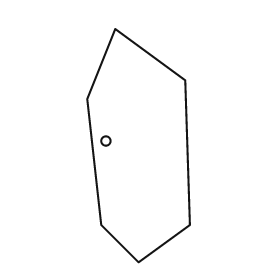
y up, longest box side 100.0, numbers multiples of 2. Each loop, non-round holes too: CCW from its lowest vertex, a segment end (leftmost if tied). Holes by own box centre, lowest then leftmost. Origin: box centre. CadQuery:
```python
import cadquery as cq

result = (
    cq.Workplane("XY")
    .moveTo(0.0, -50.0)
    .lineTo(22.0, -34.0)
    .lineTo(20.0, 28.0)
    .lineTo(-10.0, 50.0)
    .lineTo(-22.0, 20.0)
    .lineTo(-16.0, -34.0)
    .close()
    .moveTo(-14.0, 2.0)
    .circle(2.0)
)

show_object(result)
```